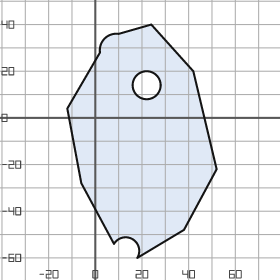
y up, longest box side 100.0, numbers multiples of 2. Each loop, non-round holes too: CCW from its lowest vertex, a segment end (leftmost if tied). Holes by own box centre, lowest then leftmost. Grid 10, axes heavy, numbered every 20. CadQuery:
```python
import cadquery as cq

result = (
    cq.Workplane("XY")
    .moveTo(18.0, -60.0)
    .lineTo(38.0, -48.0)
    .lineTo(52.0, -22.0)
    .lineTo(42.0, 20.0)
    .lineTo(24.0, 40.0)
    .lineTo(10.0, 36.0)
    .threePointArc((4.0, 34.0), (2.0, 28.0))
    .lineTo(-12.0, 4.0)
    .lineTo(-6.0, -28.0)
    .lineTo(8.0, -54.0)
    .threePointArc((16.0, -52.0), (18.0, -60.0))
    .close()
    .moveTo(22.0, 14.0)
    .circle(6.0)
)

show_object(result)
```